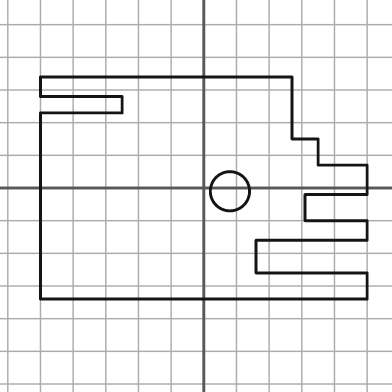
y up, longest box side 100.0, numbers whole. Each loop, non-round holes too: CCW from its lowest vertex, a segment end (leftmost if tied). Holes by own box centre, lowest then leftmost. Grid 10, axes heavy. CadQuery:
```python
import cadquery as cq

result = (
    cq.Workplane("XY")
    .moveTo(-50.0, -34.0)
    .lineTo(50.0, -34.0)
    .lineTo(50.0, -26.0)
    .lineTo(16.0, -26.0)
    .lineTo(16.0, -16.0)
    .lineTo(50.0, -16.0)
    .lineTo(50.0, -10.0)
    .lineTo(31.0, -10.0)
    .lineTo(31.0, -2.0)
    .lineTo(50.0, -2.0)
    .lineTo(50.0, 7.0)
    .lineTo(35.0, 7.0)
    .lineTo(35.0, 15.0)
    .lineTo(27.0, 15.0)
    .lineTo(27.0, 34.0)
    .lineTo(-50.0, 34.0)
    .lineTo(-50.0, 28.0)
    .lineTo(-25.0, 28.0)
    .lineTo(-25.0, 23.0)
    .lineTo(-50.0, 23.0)
    .close()
    .moveTo(8.0, -1.0)
    .circle(6.0)
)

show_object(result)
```